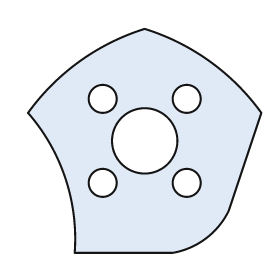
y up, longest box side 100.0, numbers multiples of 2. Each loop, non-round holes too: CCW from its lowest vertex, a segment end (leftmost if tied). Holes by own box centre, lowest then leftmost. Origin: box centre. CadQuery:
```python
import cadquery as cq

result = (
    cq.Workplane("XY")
    .moveTo(-30.0, -48.0)
    .lineTo(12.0, -48.0)
    .threePointArc((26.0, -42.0), (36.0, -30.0))
    .lineTo(50.0, 12.0)
    .threePointArc((28.0, 34.0), (0.0, 48.0))
    .threePointArc((-28.0, 34.0), (-50.0, 12.0))
    .threePointArc((-34.0, -16.0), (-30.0, -48.0))
    .close()
    .moveTo(-18.0, -18.0)
    .circle(6.0)
    .moveTo(18.0, -18.0)
    .circle(6.0)
    .moveTo(0.0, 0.0)
    .circle(14.0)
    .moveTo(-18.0, 18.0)
    .circle(6.0)
    .moveTo(18.0, 18.0)
    .circle(6.0)
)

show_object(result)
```